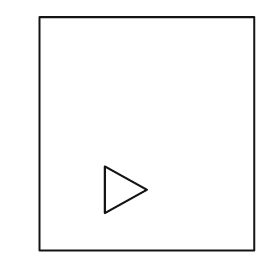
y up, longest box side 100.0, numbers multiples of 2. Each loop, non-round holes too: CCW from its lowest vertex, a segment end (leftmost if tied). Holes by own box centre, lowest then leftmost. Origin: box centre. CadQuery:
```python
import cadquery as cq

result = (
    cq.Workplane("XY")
    .moveTo(-46.0, -50.0)
    .lineTo(46.0, -50.0)
    .lineTo(46.0, 50.0)
    .lineTo(-46.0, 50.0)
    .close()
    .moveTo(-18.0, -34.0)
    .lineTo(0.0, -24.0)
    .lineTo(-18.0, -14.0)
    .close()
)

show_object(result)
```